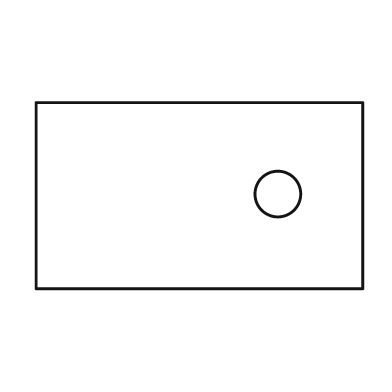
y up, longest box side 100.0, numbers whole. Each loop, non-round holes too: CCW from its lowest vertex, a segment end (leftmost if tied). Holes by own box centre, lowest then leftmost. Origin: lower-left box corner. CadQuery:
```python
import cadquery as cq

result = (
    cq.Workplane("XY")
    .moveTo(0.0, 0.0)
    .lineTo(100.0, 0.0)
    .lineTo(100.0, 57.0)
    .lineTo(0.0, 57.0)
    .close()
    .moveTo(74.0, 29.0)
    .circle(7.0)
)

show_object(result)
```